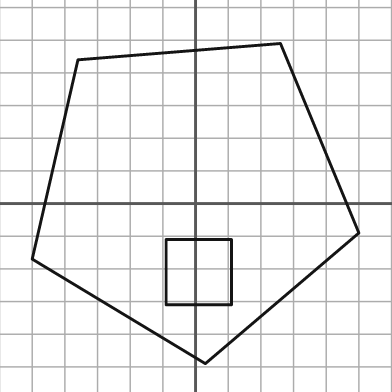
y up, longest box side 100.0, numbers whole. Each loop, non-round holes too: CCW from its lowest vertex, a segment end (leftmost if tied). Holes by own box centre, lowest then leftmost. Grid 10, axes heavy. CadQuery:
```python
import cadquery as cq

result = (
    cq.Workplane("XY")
    .moveTo(3.0, -49.0)
    .lineTo(50.0, -9.0)
    .lineTo(26.0, 49.0)
    .lineTo(-36.0, 44.0)
    .lineTo(-50.0, -17.0)
    .close()
    .moveTo(-9.0, -31.0)
    .lineTo(11.0, -31.0)
    .lineTo(11.0, -11.0)
    .lineTo(-9.0, -11.0)
    .close()
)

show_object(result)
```